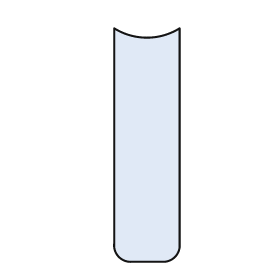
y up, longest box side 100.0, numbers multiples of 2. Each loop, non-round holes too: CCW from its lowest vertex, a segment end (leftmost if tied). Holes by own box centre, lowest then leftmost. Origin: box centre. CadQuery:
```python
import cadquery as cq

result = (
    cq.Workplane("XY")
    .moveTo(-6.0, -50.0)
    .lineTo(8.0, -50.0)
    .threePointArc((12.0, -48.0), (14.0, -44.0))
    .lineTo(14.0, 50.0)
    .threePointArc((0.0, 46.0), (-14.0, 50.0))
    .lineTo(-14.0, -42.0)
    .threePointArc((-12.0, -48.0), (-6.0, -50.0))
    .close()
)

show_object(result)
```